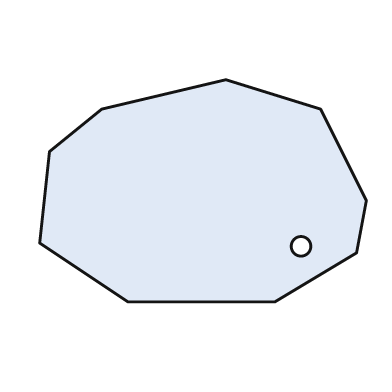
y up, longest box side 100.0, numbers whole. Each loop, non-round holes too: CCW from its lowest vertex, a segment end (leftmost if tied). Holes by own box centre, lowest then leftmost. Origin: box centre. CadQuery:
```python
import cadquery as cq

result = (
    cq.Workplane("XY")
    .moveTo(-23.0, -34.0)
    .lineTo(22.0, -34.0)
    .lineTo(47.0, -19.0)
    .lineTo(50.0, -3.0)
    .lineTo(36.0, 25.0)
    .lineTo(7.0, 34.0)
    .lineTo(-31.0, 25.0)
    .lineTo(-47.0, 12.0)
    .lineTo(-50.0, -16.0)
    .close()
    .moveTo(30.0, -17.0)
    .circle(3.0)
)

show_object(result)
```